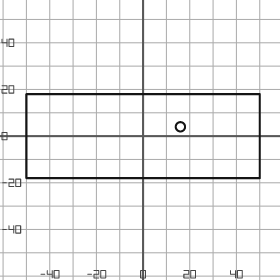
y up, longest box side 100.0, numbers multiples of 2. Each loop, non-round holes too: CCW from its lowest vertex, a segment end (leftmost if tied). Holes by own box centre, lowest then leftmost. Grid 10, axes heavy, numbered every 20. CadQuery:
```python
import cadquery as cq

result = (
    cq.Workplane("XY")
    .moveTo(-50.0, -18.0)
    .lineTo(50.0, -18.0)
    .lineTo(50.0, 18.0)
    .lineTo(-50.0, 18.0)
    .close()
    .moveTo(16.0, 4.0)
    .circle(2.0)
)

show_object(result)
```